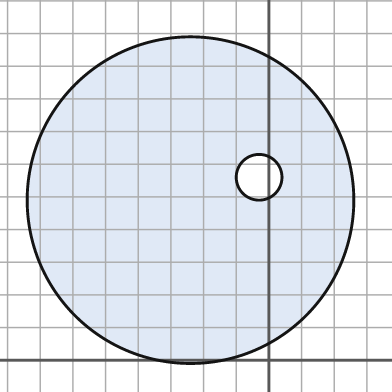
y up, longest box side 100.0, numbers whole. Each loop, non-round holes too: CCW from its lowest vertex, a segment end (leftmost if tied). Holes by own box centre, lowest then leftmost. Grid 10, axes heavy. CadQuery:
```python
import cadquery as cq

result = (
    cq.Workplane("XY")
    .moveTo(-24.0, 49.0)
    .circle(50.0)
    .moveTo(-3.0, 56.0)
    .circle(7.0)
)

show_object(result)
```